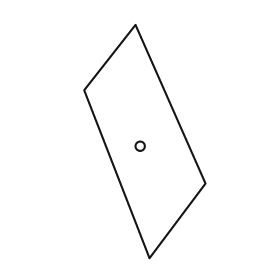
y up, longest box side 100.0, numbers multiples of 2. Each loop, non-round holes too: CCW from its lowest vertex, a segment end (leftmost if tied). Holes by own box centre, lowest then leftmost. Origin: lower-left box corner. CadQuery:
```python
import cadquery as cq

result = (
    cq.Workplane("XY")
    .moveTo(28.0, 0.0)
    .lineTo(52.0, 32.0)
    .lineTo(22.0, 100.0)
    .lineTo(0.0, 72.0)
    .close()
    .moveTo(24.0, 48.0)
    .circle(2.0)
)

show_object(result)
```